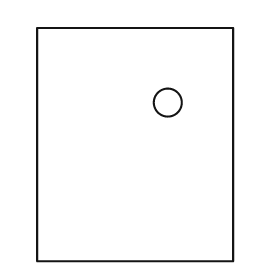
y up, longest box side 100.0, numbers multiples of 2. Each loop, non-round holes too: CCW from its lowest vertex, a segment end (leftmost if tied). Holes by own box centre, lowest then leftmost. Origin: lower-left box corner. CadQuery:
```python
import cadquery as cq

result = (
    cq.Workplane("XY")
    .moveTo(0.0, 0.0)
    .lineTo(84.0, 0.0)
    .lineTo(84.0, 100.0)
    .lineTo(0.0, 100.0)
    .close()
    .moveTo(56.0, 68.0)
    .circle(6.0)
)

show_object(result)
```